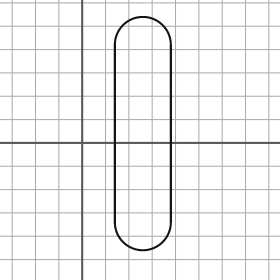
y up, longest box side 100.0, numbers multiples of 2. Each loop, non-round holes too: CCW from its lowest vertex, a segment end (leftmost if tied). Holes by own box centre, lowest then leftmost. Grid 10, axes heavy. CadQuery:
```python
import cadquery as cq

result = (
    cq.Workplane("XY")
    .moveTo(14.0, -34.0)
    .threePointArc((26.0, -46.0), (38.0, -34.0))
    .lineTo(38.0, 42.0)
    .threePointArc((26.0, 54.0), (14.0, 42.0))
    .close()
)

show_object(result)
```